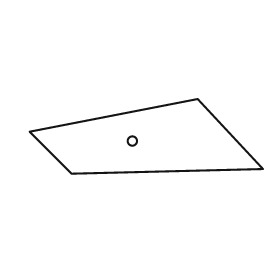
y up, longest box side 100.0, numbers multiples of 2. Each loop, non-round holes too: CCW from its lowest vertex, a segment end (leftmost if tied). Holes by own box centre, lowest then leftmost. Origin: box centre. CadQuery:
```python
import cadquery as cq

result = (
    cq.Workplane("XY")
    .moveTo(-32.0, -16.0)
    .lineTo(50.0, -14.0)
    .lineTo(22.0, 16.0)
    .lineTo(-50.0, 2.0)
    .close()
    .moveTo(-6.0, -2.0)
    .circle(2.0)
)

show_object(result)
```